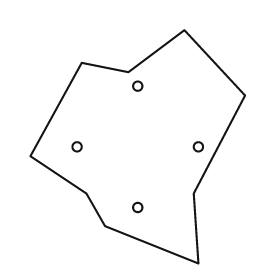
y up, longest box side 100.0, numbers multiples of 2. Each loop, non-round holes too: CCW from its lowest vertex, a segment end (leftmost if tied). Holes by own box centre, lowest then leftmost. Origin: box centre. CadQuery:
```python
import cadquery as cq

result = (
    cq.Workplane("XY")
    .moveTo(26.0, -50.0)
    .lineTo(24.0, -20.0)
    .lineTo(46.0, 22.0)
    .lineTo(20.0, 50.0)
    .lineTo(-4.0, 32.0)
    .lineTo(-24.0, 36.0)
    .lineTo(-46.0, -4.0)
    .lineTo(-22.0, -20.0)
    .lineTo(-14.0, -34.0)
    .close()
    .moveTo(0.0, -26.0)
    .circle(2.0)
    .moveTo(-26.0, 0.0)
    .circle(2.0)
    .moveTo(26.0, 0.0)
    .circle(2.0)
    .moveTo(0.0, 26.0)
    .circle(2.0)
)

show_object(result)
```